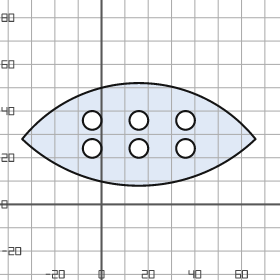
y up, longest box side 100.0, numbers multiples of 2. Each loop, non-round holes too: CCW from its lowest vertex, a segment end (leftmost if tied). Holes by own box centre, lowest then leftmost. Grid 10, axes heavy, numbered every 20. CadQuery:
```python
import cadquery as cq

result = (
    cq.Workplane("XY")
    .moveTo(-34.0, 28.0)
    .threePointArc((16.0, 8.0), (66.0, 28.0))
    .threePointArc((16.0, 52.0), (-34.0, 28.0))
    .close()
    .moveTo(-4.0, 24.0)
    .circle(4.0)
    .moveTo(16.0, 24.0)
    .circle(4.0)
    .moveTo(36.0, 24.0)
    .circle(4.0)
    .moveTo(-4.0, 36.0)
    .circle(4.0)
    .moveTo(16.0, 36.0)
    .circle(4.0)
    .moveTo(36.0, 36.0)
    .circle(4.0)
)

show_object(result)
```